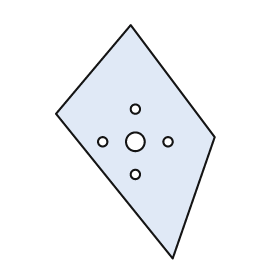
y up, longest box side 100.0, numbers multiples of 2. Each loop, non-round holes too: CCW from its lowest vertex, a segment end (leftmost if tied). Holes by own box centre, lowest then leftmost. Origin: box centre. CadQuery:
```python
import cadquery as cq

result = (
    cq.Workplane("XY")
    .moveTo(16.0, -50.0)
    .lineTo(34.0, 2.0)
    .lineTo(-2.0, 50.0)
    .lineTo(-34.0, 12.0)
    .close()
    .moveTo(0.0, -14.0)
    .circle(2.0)
    .moveTo(-14.0, 0.0)
    .circle(2.0)
    .moveTo(0.0, 0.0)
    .circle(4.0)
    .moveTo(14.0, 0.0)
    .circle(2.0)
    .moveTo(0.0, 14.0)
    .circle(2.0)
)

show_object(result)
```